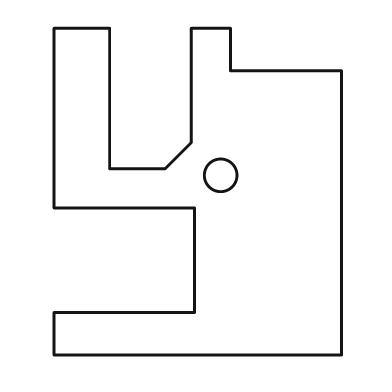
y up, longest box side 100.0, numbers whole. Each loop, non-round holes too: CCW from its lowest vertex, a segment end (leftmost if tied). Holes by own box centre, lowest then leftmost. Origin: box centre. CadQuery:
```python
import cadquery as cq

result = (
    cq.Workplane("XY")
    .moveTo(-44.0, -50.0)
    .lineTo(44.0, -50.0)
    .lineTo(44.0, 37.0)
    .lineTo(10.0, 37.0)
    .lineTo(10.0, 50.0)
    .lineTo(-2.0, 50.0)
    .lineTo(-2.0, 15.0)
    .lineTo(-10.0, 7.0)
    .lineTo(-27.0, 7.0)
    .lineTo(-27.0, 50.0)
    .lineTo(-44.0, 50.0)
    .lineTo(-44.0, -5.0)
    .lineTo(-1.0, -5.0)
    .lineTo(-1.0, -37.0)
    .lineTo(-44.0, -37.0)
    .close()
    .moveTo(7.0, 5.0)
    .circle(5.0)
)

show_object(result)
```